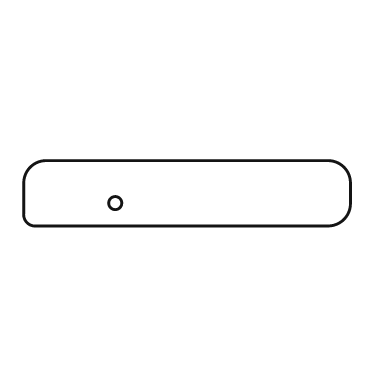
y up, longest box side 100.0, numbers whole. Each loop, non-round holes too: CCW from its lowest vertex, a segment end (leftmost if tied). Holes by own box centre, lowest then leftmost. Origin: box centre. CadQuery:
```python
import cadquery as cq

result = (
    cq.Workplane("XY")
    .moveTo(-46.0, -10.0)
    .lineTo(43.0, -10.0)
    .threePointArc((48.0, -8.0), (50.0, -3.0))
    .lineTo(50.0, 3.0)
    .threePointArc((48.0, 8.0), (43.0, 10.0))
    .lineTo(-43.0, 10.0)
    .threePointArc((-48.0, 8.0), (-50.0, 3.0))
    .lineTo(-50.0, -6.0)
    .threePointArc((-49.0, -9.0), (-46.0, -10.0))
    .close()
    .moveTo(-22.0, -3.0)
    .circle(2.0)
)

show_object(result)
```